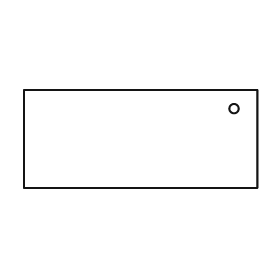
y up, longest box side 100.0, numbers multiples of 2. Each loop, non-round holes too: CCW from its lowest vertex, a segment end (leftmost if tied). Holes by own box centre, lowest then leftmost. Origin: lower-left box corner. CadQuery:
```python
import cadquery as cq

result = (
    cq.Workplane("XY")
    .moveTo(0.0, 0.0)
    .lineTo(100.0, 0.0)
    .lineTo(100.0, 42.0)
    .lineTo(0.0, 42.0)
    .close()
    .moveTo(90.0, 34.0)
    .circle(2.0)
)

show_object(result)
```